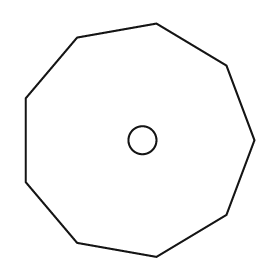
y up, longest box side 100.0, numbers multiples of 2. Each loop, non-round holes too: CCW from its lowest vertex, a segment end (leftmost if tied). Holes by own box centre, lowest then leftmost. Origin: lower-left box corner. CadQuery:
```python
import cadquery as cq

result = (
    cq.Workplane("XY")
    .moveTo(56.0, 0.0)
    .lineTo(86.0, 18.0)
    .lineTo(98.0, 50.0)
    .lineTo(86.0, 82.0)
    .lineTo(56.0, 100.0)
    .lineTo(22.0, 94.0)
    .lineTo(0.0, 68.0)
    .lineTo(0.0, 32.0)
    .lineTo(22.0, 6.0)
    .close()
    .moveTo(50.0, 50.0)
    .circle(6.0)
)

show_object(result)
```